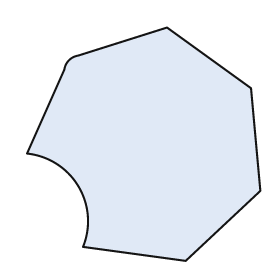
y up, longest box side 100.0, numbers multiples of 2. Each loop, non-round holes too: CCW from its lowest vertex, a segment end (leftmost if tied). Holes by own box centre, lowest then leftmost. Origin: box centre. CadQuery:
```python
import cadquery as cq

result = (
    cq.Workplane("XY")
    .moveTo(18.0, -50.0)
    .lineTo(50.0, -20.0)
    .lineTo(46.0, 24.0)
    .lineTo(10.0, 50.0)
    .lineTo(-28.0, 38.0)
    .threePointArc((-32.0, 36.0), (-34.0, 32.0))
    .lineTo(-50.0, -4.0)
    .threePointArc((-28.0, -18.0), (-26.0, -44.0))
    .close()
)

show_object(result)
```